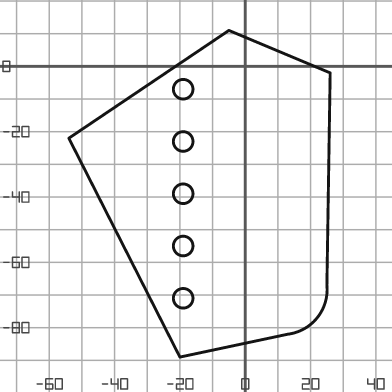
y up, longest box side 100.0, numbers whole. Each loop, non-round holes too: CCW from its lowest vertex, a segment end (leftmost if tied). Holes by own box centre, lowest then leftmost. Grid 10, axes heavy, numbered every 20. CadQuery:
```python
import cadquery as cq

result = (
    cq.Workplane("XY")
    .moveTo(-20.0, -89.0)
    .lineTo(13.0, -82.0)
    .threePointArc((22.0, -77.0), (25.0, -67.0))
    .lineTo(26.0, -2.0)
    .lineTo(-5.0, 11.0)
    .lineTo(-54.0, -22.0)
    .close()
    .moveTo(-19.0, -71.0)
    .circle(3.0)
    .moveTo(-19.0, -55.0)
    .circle(3.0)
    .moveTo(-19.0, -39.0)
    .circle(3.0)
    .moveTo(-19.0, -23.0)
    .circle(3.0)
    .moveTo(-19.0, -7.0)
    .circle(3.0)
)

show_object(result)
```